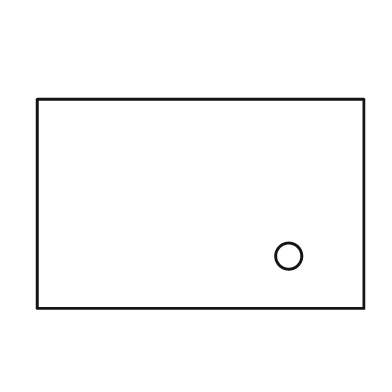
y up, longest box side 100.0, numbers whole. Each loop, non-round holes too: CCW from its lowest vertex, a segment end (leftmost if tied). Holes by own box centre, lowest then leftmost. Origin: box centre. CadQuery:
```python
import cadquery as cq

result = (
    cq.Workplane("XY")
    .moveTo(-50.0, -32.0)
    .lineTo(50.0, -32.0)
    .lineTo(50.0, 32.0)
    .lineTo(-50.0, 32.0)
    .close()
    .moveTo(27.0, -16.0)
    .circle(4.0)
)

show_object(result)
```